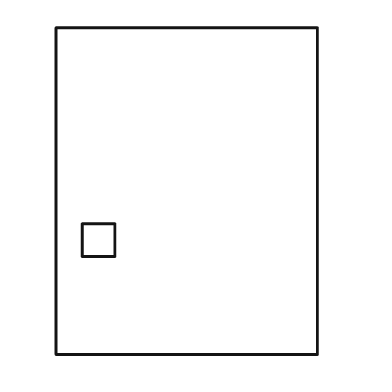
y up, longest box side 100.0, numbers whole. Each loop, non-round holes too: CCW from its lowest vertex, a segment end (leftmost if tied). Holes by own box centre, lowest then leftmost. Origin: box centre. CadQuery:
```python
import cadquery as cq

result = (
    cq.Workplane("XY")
    .moveTo(-40.0, -50.0)
    .lineTo(40.0, -50.0)
    .lineTo(40.0, 50.0)
    .lineTo(-40.0, 50.0)
    .close()
    .moveTo(-32.0, -20.0)
    .lineTo(-22.0, -20.0)
    .lineTo(-22.0, -10.0)
    .lineTo(-32.0, -10.0)
    .close()
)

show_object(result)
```